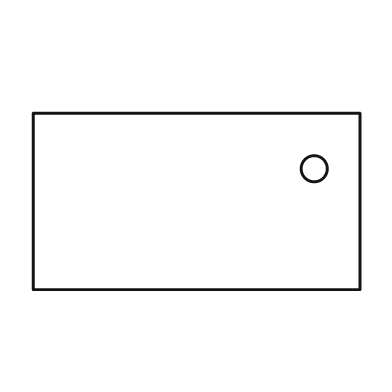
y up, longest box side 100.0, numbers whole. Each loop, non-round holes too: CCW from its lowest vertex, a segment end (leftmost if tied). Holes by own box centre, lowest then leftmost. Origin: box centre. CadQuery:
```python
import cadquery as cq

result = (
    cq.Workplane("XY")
    .moveTo(-50.0, -27.0)
    .lineTo(50.0, -27.0)
    .lineTo(50.0, 27.0)
    .lineTo(-50.0, 27.0)
    .close()
    .moveTo(36.0, 10.0)
    .circle(4.0)
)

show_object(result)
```